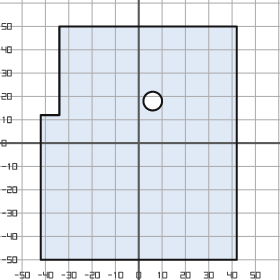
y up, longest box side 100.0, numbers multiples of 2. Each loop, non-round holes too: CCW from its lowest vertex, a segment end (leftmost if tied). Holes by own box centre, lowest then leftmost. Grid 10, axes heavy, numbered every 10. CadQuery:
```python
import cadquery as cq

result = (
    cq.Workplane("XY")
    .moveTo(-42.0, -50.0)
    .lineTo(42.0, -50.0)
    .lineTo(42.0, 50.0)
    .lineTo(-34.0, 50.0)
    .lineTo(-34.0, 12.0)
    .lineTo(-42.0, 12.0)
    .close()
    .moveTo(6.0, 18.0)
    .circle(4.0)
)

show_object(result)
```